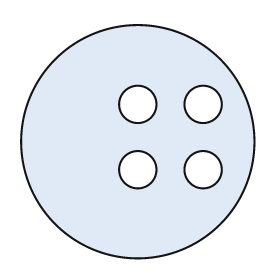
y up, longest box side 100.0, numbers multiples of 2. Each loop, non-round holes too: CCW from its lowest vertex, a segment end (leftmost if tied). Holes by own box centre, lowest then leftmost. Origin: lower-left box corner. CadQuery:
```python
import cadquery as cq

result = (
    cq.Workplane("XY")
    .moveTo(50.0, 50.0)
    .circle(50.0)
    .moveTo(50.0, 38.0)
    .circle(8.0)
    .moveTo(78.0, 38.0)
    .circle(8.0)
    .moveTo(50.0, 66.0)
    .circle(8.0)
    .moveTo(78.0, 66.0)
    .circle(8.0)
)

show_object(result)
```